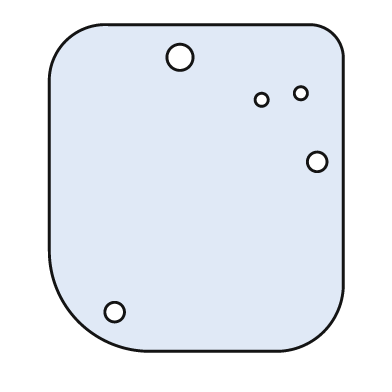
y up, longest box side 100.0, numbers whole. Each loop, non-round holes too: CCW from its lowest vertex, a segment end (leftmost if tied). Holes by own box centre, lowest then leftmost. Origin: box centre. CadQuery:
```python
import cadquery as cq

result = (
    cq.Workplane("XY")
    .moveTo(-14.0, -50.0)
    .lineTo(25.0, -50.0)
    .threePointArc((39.0, -44.0), (45.0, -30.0))
    .lineTo(45.0, 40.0)
    .threePointArc((42.0, 47.0), (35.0, 50.0))
    .lineTo(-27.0, 50.0)
    .threePointArc((-40.0, 45.0), (-45.0, 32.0))
    .lineTo(-45.0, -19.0)
    .threePointArc((-36.0, -41.0), (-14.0, -50.0))
    .close()
    .moveTo(-25.0, -38.0)
    .circle(3.0)
    .moveTo(37.0, 8.0)
    .circle(3.0)
    .moveTo(20.0, 27.0)
    .circle(2.0)
    .moveTo(32.0, 29.0)
    .circle(2.0)
    .moveTo(-5.0, 40.0)
    .circle(4.0)
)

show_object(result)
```